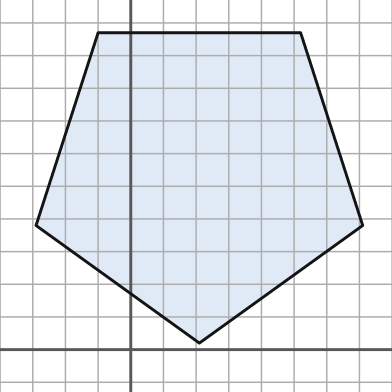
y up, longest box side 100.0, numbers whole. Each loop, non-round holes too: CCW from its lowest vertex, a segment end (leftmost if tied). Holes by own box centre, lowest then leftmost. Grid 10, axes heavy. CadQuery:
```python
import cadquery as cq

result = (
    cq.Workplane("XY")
    .moveTo(21.0, 2.0)
    .lineTo(71.0, 38.0)
    .lineTo(52.0, 97.0)
    .lineTo(-10.0, 97.0)
    .lineTo(-29.0, 38.0)
    .close()
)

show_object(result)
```